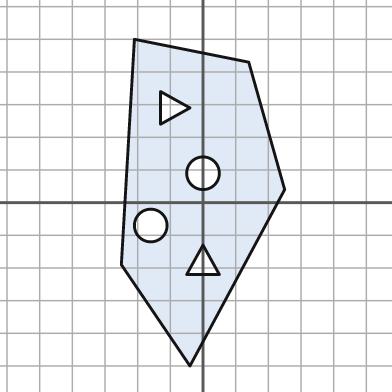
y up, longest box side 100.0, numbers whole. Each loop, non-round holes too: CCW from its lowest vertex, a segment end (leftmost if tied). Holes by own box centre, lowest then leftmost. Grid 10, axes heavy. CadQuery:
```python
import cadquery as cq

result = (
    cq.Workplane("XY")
    .moveTo(-4.0, -50.0)
    .lineTo(25.0, 4.0)
    .lineTo(14.0, 43.0)
    .lineTo(-21.0, 50.0)
    .lineTo(-25.0, -19.0)
    .close()
    .moveTo(-5.0, -22.0)
    .lineTo(5.0, -22.0)
    .lineTo(0.0, -13.0)
    .close()
    .moveTo(-16.0, -7.0)
    .circle(5.0)
    .moveTo(0.0, 9.0)
    .circle(5.0)
    .moveTo(-13.0, 24.0)
    .lineTo(-4.0, 29.0)
    .lineTo(-13.0, 34.0)
    .close()
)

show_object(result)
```